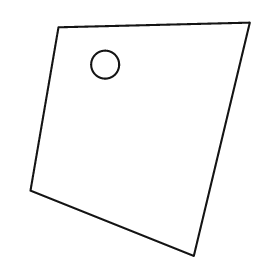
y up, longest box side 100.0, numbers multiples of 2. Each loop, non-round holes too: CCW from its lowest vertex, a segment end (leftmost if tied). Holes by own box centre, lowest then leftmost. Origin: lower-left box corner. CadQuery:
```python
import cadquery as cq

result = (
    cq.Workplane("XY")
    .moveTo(70.0, 0.0)
    .lineTo(94.0, 100.0)
    .lineTo(12.0, 98.0)
    .lineTo(0.0, 28.0)
    .close()
    .moveTo(32.0, 82.0)
    .circle(6.0)
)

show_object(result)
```